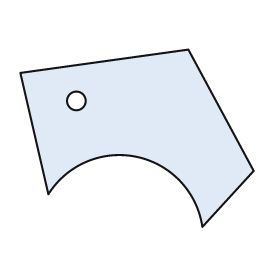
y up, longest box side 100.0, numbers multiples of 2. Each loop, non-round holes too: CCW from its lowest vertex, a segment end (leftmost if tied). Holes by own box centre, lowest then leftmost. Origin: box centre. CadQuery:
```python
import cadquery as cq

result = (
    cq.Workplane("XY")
    .moveTo(28.0, -38.0)
    .lineTo(50.0, -14.0)
    .lineTo(22.0, 38.0)
    .lineTo(-50.0, 28.0)
    .lineTo(-38.0, -24.0)
    .threePointArc((0.0, -8.0), (28.0, -38.0))
    .close()
    .moveTo(-26.0, 16.0)
    .circle(4.0)
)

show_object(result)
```